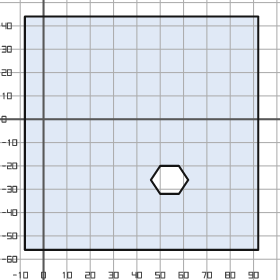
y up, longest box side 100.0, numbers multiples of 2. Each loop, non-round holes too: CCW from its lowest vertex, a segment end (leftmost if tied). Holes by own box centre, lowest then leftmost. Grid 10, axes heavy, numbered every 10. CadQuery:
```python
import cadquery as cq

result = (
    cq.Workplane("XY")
    .moveTo(-8.0, -56.0)
    .lineTo(92.0, -56.0)
    .lineTo(92.0, 44.0)
    .lineTo(-8.0, 44.0)
    .close()
    .moveTo(50.0, -32.0)
    .lineTo(58.0, -32.0)
    .lineTo(62.0, -26.0)
    .lineTo(58.0, -20.0)
    .lineTo(50.0, -20.0)
    .lineTo(46.0, -26.0)
    .close()
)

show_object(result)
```